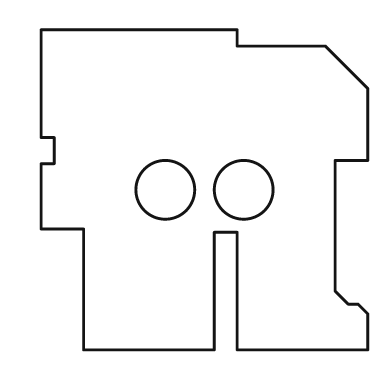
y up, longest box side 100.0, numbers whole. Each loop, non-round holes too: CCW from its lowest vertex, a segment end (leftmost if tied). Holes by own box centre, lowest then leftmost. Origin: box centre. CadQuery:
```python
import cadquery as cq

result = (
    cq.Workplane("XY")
    .moveTo(-37.0, -49.0)
    .lineTo(3.0, -49.0)
    .lineTo(3.0, -13.0)
    .lineTo(10.0, -13.0)
    .lineTo(10.0, -49.0)
    .lineTo(50.0, -49.0)
    .lineTo(50.0, -38.0)
    .lineTo(47.0, -35.0)
    .lineTo(44.0, -35.0)
    .lineTo(40.0, -31.0)
    .lineTo(40.0, 9.0)
    .lineTo(50.0, 9.0)
    .lineTo(50.0, 31.0)
    .lineTo(37.0, 44.0)
    .lineTo(10.0, 44.0)
    .lineTo(10.0, 49.0)
    .lineTo(-50.0, 49.0)
    .lineTo(-50.0, 16.0)
    .lineTo(-46.0, 16.0)
    .lineTo(-46.0, 8.0)
    .lineTo(-50.0, 8.0)
    .lineTo(-50.0, -12.0)
    .lineTo(-37.0, -12.0)
    .close()
    .moveTo(-12.0, 0.0)
    .circle(9.0)
    .moveTo(12.0, 0.0)
    .circle(9.0)
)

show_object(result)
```